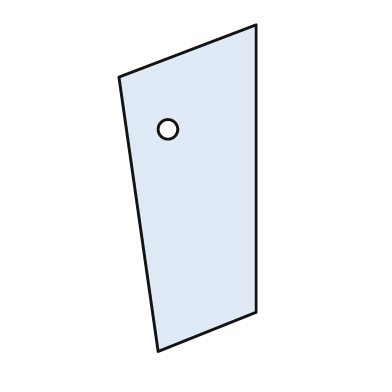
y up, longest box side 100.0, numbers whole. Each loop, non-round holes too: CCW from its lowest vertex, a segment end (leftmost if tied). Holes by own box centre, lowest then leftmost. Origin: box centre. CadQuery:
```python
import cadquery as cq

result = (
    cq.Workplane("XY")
    .moveTo(-9.0, -50.0)
    .lineTo(21.0, -38.0)
    .lineTo(21.0, 50.0)
    .lineTo(-21.0, 34.0)
    .close()
    .moveTo(-6.0, 18.0)
    .circle(3.0)
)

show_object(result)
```